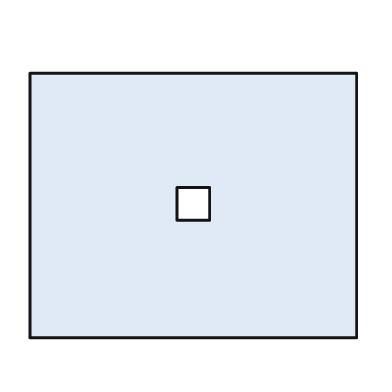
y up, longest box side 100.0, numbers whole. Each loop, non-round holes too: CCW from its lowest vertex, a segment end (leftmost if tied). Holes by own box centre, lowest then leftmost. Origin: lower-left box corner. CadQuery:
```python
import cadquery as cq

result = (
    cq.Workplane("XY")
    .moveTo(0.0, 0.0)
    .lineTo(100.0, 0.0)
    .lineTo(100.0, 81.0)
    .lineTo(0.0, 81.0)
    .close()
    .moveTo(45.0, 36.0)
    .lineTo(55.0, 36.0)
    .lineTo(55.0, 46.0)
    .lineTo(45.0, 46.0)
    .close()
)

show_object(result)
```